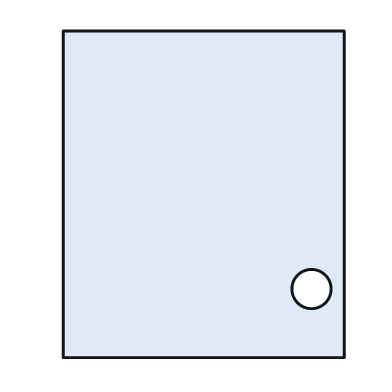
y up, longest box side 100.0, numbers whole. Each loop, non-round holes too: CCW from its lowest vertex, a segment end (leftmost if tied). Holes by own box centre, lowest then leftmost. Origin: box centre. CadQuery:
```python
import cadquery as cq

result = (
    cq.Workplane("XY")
    .moveTo(-43.0, -50.0)
    .lineTo(43.0, -50.0)
    .lineTo(43.0, 50.0)
    .lineTo(-43.0, 50.0)
    .close()
    .moveTo(33.0, -29.0)
    .circle(6.0)
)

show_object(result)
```